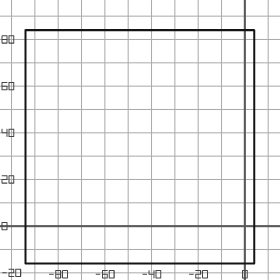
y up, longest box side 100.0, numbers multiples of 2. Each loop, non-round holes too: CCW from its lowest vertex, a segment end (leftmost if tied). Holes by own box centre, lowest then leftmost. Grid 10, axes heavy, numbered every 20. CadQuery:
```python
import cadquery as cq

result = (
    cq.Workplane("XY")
    .moveTo(-94.0, -16.0)
    .lineTo(4.0, -16.0)
    .lineTo(4.0, 84.0)
    .lineTo(-94.0, 84.0)
    .close()
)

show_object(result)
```